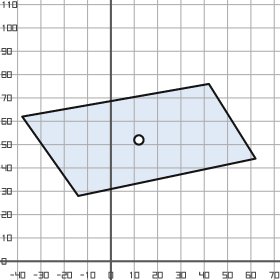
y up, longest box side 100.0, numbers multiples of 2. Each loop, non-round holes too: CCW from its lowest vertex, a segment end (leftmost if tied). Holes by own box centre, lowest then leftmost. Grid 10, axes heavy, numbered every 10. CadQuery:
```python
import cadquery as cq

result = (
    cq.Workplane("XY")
    .moveTo(-14.0, 28.0)
    .lineTo(62.0, 44.0)
    .lineTo(42.0, 76.0)
    .lineTo(-38.0, 62.0)
    .close()
    .moveTo(12.0, 52.0)
    .circle(2.0)
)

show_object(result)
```